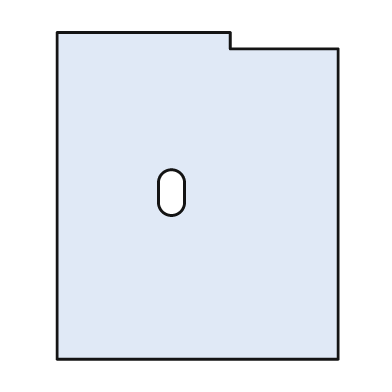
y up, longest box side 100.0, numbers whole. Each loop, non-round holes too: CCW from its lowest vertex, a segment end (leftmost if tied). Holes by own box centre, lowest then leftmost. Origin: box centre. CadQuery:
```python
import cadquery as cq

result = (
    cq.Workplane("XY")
    .moveTo(-43.0, -50.0)
    .lineTo(43.0, -50.0)
    .lineTo(43.0, 45.0)
    .lineTo(10.0, 45.0)
    .lineTo(10.0, 50.0)
    .lineTo(-43.0, 50.0)
    .close()
    .moveTo(-12.0, -2.0)
    .threePointArc((-8.0, -6.0), (-4.0, -2.0))
    .lineTo(-4.0, 4.0)
    .threePointArc((-8.0, 8.0), (-12.0, 4.0))
    .close()
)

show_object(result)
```